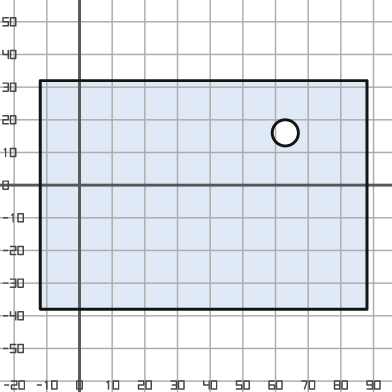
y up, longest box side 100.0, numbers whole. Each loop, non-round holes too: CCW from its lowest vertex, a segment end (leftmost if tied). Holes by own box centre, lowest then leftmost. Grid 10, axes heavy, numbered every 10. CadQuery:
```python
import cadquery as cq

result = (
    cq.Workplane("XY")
    .moveTo(-12.0, -38.0)
    .lineTo(88.0, -38.0)
    .lineTo(88.0, 32.0)
    .lineTo(-12.0, 32.0)
    .close()
    .moveTo(63.0, 16.0)
    .circle(4.0)
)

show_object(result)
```